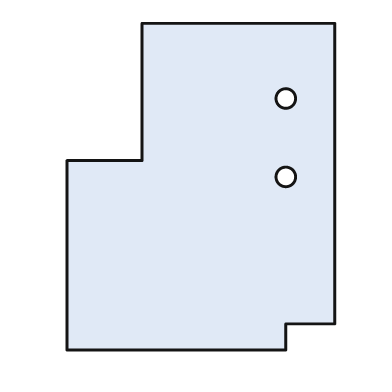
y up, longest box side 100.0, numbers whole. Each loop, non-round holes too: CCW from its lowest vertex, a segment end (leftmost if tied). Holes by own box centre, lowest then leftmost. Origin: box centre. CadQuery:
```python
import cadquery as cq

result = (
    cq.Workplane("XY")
    .moveTo(-41.0, -50.0)
    .lineTo(26.0, -50.0)
    .lineTo(26.0, -42.0)
    .lineTo(41.0, -42.0)
    .lineTo(41.0, 50.0)
    .lineTo(-18.0, 50.0)
    .lineTo(-18.0, 8.0)
    .lineTo(-41.0, 8.0)
    .close()
    .moveTo(26.0, 3.0)
    .circle(3.0)
    .moveTo(26.0, 27.0)
    .circle(3.0)
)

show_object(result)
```